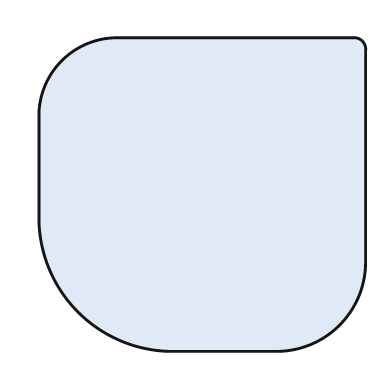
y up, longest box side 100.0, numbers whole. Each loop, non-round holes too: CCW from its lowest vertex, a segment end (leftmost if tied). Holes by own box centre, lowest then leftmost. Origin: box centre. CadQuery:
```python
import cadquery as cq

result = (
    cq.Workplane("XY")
    .moveTo(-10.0, -48.0)
    .lineTo(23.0, -48.0)
    .threePointArc((42.0, -40.0), (50.0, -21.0))
    .lineTo(50.0, 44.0)
    .threePointArc((49.0, 47.0), (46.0, 48.0))
    .lineTo(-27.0, 48.0)
    .threePointArc((-43.0, 41.0), (-50.0, 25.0))
    .lineTo(-50.0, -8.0)
    .threePointArc((-38.0, -36.0), (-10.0, -48.0))
    .close()
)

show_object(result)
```